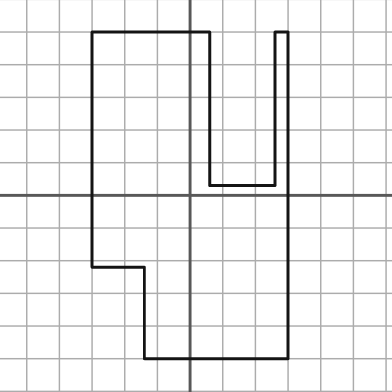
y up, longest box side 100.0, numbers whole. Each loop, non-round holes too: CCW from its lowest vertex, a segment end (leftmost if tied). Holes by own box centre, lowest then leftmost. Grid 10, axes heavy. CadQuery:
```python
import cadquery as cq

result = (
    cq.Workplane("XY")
    .moveTo(-14.0, -50.0)
    .lineTo(30.0, -50.0)
    .lineTo(30.0, 50.0)
    .lineTo(26.0, 50.0)
    .lineTo(26.0, 3.0)
    .lineTo(6.0, 3.0)
    .lineTo(6.0, 50.0)
    .lineTo(-30.0, 50.0)
    .lineTo(-30.0, -22.0)
    .lineTo(-14.0, -22.0)
    .close()
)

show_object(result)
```